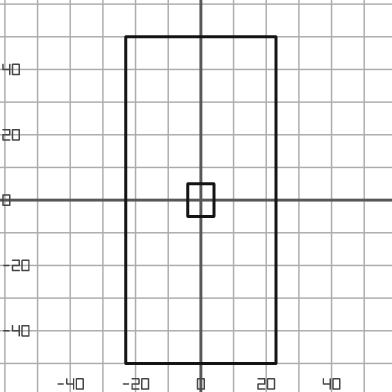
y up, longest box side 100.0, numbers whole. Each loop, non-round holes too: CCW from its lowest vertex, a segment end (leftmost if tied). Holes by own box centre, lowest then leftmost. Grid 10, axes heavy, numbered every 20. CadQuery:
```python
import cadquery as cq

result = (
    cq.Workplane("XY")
    .moveTo(-23.0, -50.0)
    .lineTo(23.0, -50.0)
    .lineTo(23.0, 50.0)
    .lineTo(-23.0, 50.0)
    .close()
    .moveTo(-4.0, -5.0)
    .lineTo(4.0, -5.0)
    .lineTo(4.0, 5.0)
    .lineTo(-4.0, 5.0)
    .close()
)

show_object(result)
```